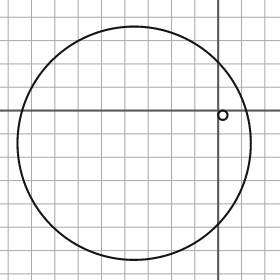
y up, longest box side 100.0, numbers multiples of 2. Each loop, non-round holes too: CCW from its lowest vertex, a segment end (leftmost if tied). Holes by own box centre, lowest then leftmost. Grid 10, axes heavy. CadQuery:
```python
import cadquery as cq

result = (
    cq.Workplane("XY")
    .moveTo(-36.0, -14.0)
    .circle(50.0)
    .moveTo(2.0, -2.0)
    .circle(2.0)
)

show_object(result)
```